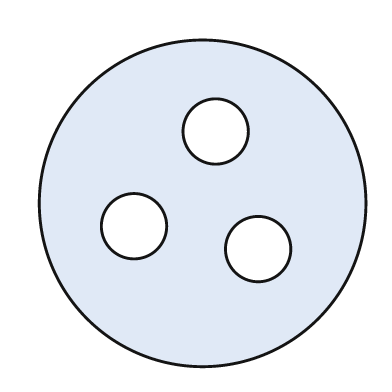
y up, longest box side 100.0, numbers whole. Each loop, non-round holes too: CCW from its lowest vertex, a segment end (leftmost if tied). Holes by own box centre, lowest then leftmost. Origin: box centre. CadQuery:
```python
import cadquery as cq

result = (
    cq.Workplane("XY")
    .moveTo(0.0, 0.0)
    .circle(50.0)
    .moveTo(17.0, -14.0)
    .circle(10.0)
    .moveTo(-21.0, -7.0)
    .circle(10.0)
    .moveTo(4.0, 22.0)
    .circle(10.0)
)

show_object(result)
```